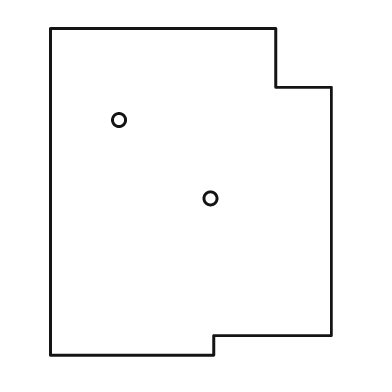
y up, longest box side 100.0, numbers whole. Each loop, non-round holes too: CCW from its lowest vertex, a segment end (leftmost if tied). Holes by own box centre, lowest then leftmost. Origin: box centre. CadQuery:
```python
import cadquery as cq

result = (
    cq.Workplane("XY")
    .moveTo(-43.0, -50.0)
    .lineTo(7.0, -50.0)
    .lineTo(7.0, -44.0)
    .lineTo(43.0, -44.0)
    .lineTo(43.0, 32.0)
    .lineTo(26.0, 32.0)
    .lineTo(26.0, 50.0)
    .lineTo(-43.0, 50.0)
    .close()
    .moveTo(6.0, -2.0)
    .circle(2.0)
    .moveTo(-22.0, 22.0)
    .circle(2.0)
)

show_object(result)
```